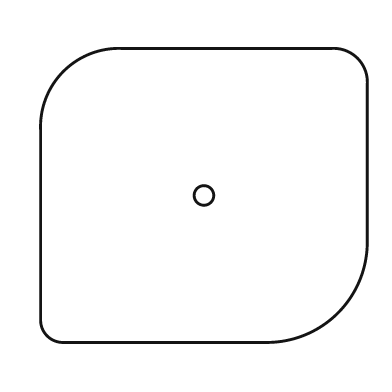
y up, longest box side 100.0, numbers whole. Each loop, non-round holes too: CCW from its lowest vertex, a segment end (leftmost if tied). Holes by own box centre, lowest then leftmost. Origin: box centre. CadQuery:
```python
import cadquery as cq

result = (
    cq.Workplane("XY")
    .moveTo(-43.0, -45.0)
    .lineTo(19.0, -45.0)
    .threePointArc((41.0, -36.0), (50.0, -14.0))
    .lineTo(50.0, 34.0)
    .threePointArc((47.0, 42.0), (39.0, 45.0))
    .lineTo(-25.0, 45.0)
    .threePointArc((-43.0, 38.0), (-50.0, 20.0))
    .lineTo(-50.0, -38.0)
    .threePointArc((-48.0, -43.0), (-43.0, -45.0))
    .close()
    .moveTo(0.0, 0.0)
    .circle(3.0)
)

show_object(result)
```